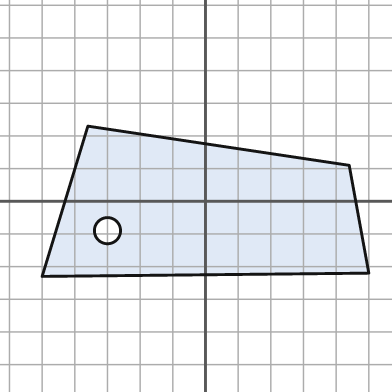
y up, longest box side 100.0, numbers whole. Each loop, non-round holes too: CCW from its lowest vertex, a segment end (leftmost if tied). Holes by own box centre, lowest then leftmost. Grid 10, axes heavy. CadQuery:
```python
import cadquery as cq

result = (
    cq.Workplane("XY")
    .moveTo(-50.0, -23.0)
    .lineTo(50.0, -22.0)
    .lineTo(44.0, 11.0)
    .lineTo(-36.0, 23.0)
    .close()
    .moveTo(-30.0, -9.0)
    .circle(4.0)
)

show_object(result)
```